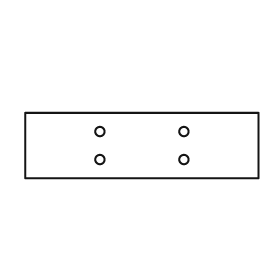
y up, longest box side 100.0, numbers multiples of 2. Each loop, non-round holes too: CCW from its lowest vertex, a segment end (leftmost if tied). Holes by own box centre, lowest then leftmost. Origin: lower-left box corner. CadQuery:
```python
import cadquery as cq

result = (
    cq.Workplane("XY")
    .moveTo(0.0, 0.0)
    .lineTo(100.0, 0.0)
    .lineTo(100.0, 28.0)
    .lineTo(0.0, 28.0)
    .close()
    .moveTo(32.0, 8.0)
    .circle(2.0)
    .moveTo(68.0, 8.0)
    .circle(2.0)
    .moveTo(32.0, 20.0)
    .circle(2.0)
    .moveTo(68.0, 20.0)
    .circle(2.0)
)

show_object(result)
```